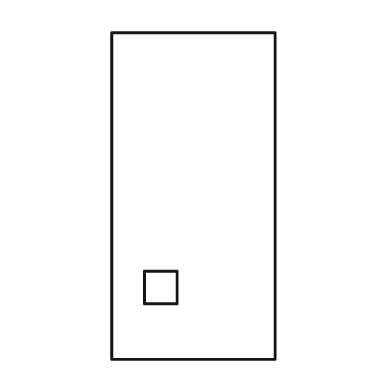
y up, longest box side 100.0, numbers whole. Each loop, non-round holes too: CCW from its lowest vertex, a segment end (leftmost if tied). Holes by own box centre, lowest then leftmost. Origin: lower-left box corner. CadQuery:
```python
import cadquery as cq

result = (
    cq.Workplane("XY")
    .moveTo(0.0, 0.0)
    .lineTo(50.0, 0.0)
    .lineTo(50.0, 100.0)
    .lineTo(0.0, 100.0)
    .close()
    .moveTo(10.0, 17.0)
    .lineTo(20.0, 17.0)
    .lineTo(20.0, 27.0)
    .lineTo(10.0, 27.0)
    .close()
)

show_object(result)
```